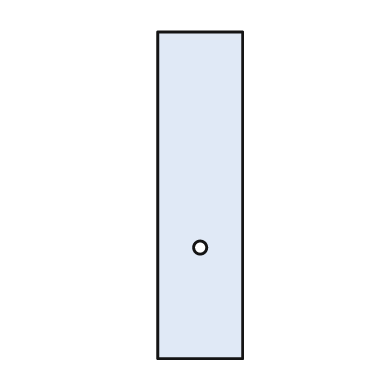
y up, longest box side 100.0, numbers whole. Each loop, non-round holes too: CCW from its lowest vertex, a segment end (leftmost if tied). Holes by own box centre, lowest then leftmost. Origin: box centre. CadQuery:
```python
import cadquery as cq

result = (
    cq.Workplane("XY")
    .moveTo(-13.0, -50.0)
    .lineTo(13.0, -50.0)
    .lineTo(13.0, 50.0)
    .lineTo(-13.0, 50.0)
    .close()
    .moveTo(0.0, -16.0)
    .circle(2.0)
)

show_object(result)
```